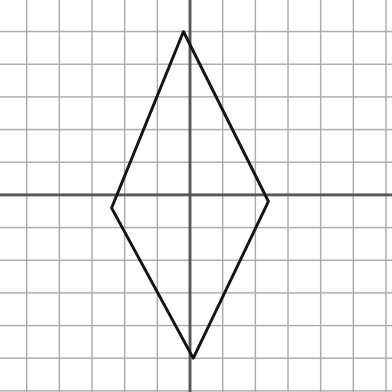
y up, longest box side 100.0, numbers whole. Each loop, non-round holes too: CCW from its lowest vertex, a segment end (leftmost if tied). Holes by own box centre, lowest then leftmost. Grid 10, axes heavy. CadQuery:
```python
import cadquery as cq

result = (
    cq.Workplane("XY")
    .moveTo(1.0, -50.0)
    .lineTo(24.0, -2.0)
    .lineTo(-2.0, 50.0)
    .lineTo(-24.0, -4.0)
    .close()
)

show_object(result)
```